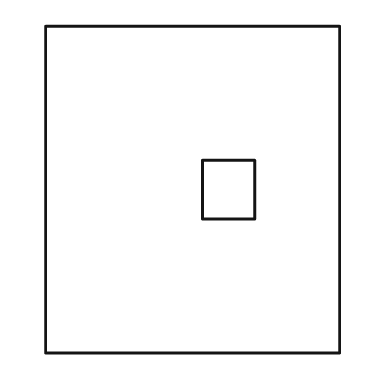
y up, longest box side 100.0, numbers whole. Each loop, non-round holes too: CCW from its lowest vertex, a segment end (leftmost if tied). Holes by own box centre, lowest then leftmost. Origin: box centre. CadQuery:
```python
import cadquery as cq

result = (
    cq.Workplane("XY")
    .moveTo(-45.0, -50.0)
    .lineTo(45.0, -50.0)
    .lineTo(45.0, 50.0)
    .lineTo(-45.0, 50.0)
    .close()
    .moveTo(3.0, -9.0)
    .lineTo(19.0, -9.0)
    .lineTo(19.0, 9.0)
    .lineTo(3.0, 9.0)
    .close()
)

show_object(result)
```